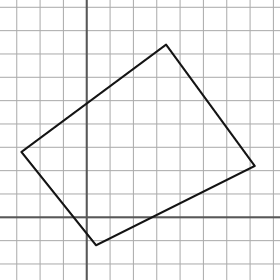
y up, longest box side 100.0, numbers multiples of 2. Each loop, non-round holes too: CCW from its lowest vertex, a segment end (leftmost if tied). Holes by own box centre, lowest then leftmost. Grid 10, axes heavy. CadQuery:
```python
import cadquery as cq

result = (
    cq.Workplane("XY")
    .moveTo(4.0, -12.0)
    .lineTo(72.0, 22.0)
    .lineTo(34.0, 74.0)
    .lineTo(-28.0, 28.0)
    .close()
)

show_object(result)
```